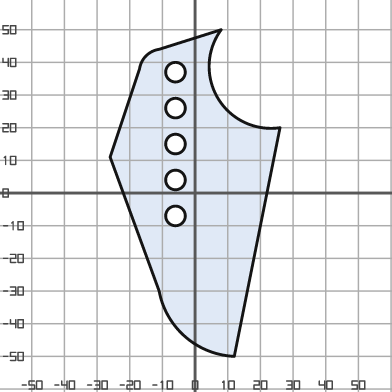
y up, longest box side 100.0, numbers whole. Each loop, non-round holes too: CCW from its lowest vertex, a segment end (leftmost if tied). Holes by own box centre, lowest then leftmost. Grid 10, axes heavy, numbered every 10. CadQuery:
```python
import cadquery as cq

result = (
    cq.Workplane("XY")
    .moveTo(12.0, -50.0)
    .lineTo(26.0, 20.0)
    .threePointArc((7.0, 29.0), (8.0, 50.0))
    .lineTo(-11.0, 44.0)
    .threePointArc((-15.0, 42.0), (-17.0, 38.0))
    .lineTo(-26.0, 11.0)
    .lineTo(-11.0, -30.0)
    .threePointArc((-3.0, -44.0), (12.0, -50.0))
    .close()
    .moveTo(-6.0, -7.0)
    .circle(3.0)
    .moveTo(-6.0, 4.0)
    .circle(3.0)
    .moveTo(-6.0, 15.0)
    .circle(3.0)
    .moveTo(-6.0, 26.0)
    .circle(3.0)
    .moveTo(-6.0, 37.0)
    .circle(3.0)
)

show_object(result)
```